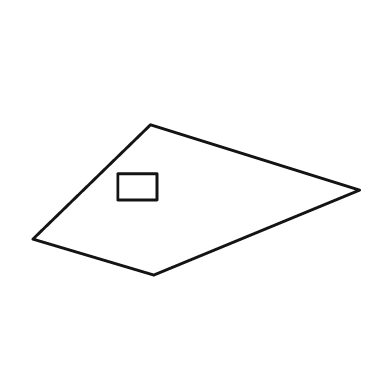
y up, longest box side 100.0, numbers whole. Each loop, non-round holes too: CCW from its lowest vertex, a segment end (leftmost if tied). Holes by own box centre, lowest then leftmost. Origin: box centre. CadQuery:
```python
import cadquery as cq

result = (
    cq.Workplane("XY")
    .moveTo(-13.0, -23.0)
    .lineTo(50.0, 3.0)
    .lineTo(-14.0, 23.0)
    .lineTo(-50.0, -12.0)
    .close()
    .moveTo(-24.0, 0.0)
    .lineTo(-12.0, 0.0)
    .lineTo(-12.0, 8.0)
    .lineTo(-24.0, 8.0)
    .close()
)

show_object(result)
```